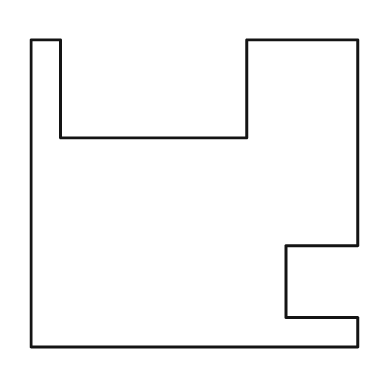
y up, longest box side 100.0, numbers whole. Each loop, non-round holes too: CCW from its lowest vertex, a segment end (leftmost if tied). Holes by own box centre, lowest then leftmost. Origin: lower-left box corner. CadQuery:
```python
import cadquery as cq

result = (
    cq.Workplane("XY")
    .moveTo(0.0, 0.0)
    .lineTo(100.0, 0.0)
    .lineTo(100.0, 9.0)
    .lineTo(78.0, 9.0)
    .lineTo(78.0, 31.0)
    .lineTo(100.0, 31.0)
    .lineTo(100.0, 94.0)
    .lineTo(66.0, 94.0)
    .lineTo(66.0, 64.0)
    .lineTo(9.0, 64.0)
    .lineTo(9.0, 94.0)
    .lineTo(0.0, 94.0)
    .close()
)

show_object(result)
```